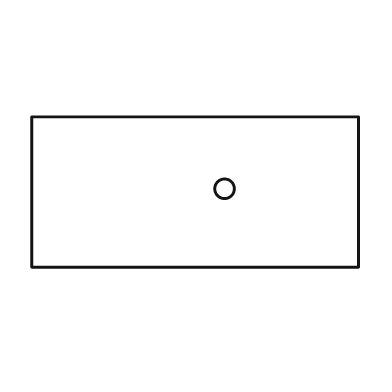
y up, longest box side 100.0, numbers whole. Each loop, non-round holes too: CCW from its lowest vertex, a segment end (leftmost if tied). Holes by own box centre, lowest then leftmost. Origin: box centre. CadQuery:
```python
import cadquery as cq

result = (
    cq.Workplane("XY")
    .moveTo(-50.0, -23.0)
    .lineTo(50.0, -23.0)
    .lineTo(50.0, 23.0)
    .lineTo(-50.0, 23.0)
    .close()
    .moveTo(9.0, 1.0)
    .circle(3.0)
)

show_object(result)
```